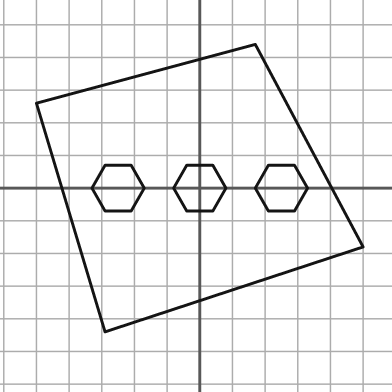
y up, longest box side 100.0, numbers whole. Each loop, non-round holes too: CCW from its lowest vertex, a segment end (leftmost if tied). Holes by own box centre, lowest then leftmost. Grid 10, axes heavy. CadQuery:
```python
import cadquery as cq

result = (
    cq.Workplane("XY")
    .moveTo(-29.0, -44.0)
    .lineTo(50.0, -18.0)
    .lineTo(17.0, 44.0)
    .lineTo(-50.0, 26.0)
    .close()
    .moveTo(-29.0, -7.0)
    .lineTo(-21.0, -7.0)
    .lineTo(-17.0, 0.0)
    .lineTo(-21.0, 7.0)
    .lineTo(-29.0, 7.0)
    .lineTo(-33.0, 0.0)
    .close()
    .moveTo(-4.0, -7.0)
    .lineTo(4.0, -7.0)
    .lineTo(8.0, 0.0)
    .lineTo(4.0, 7.0)
    .lineTo(-4.0, 7.0)
    .lineTo(-8.0, 0.0)
    .close()
    .moveTo(21.0, -7.0)
    .lineTo(29.0, -7.0)
    .lineTo(33.0, 0.0)
    .lineTo(29.0, 7.0)
    .lineTo(21.0, 7.0)
    .lineTo(17.0, 0.0)
    .close()
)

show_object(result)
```